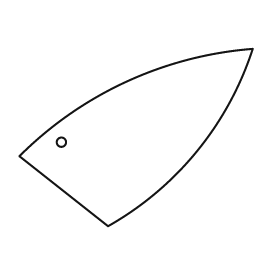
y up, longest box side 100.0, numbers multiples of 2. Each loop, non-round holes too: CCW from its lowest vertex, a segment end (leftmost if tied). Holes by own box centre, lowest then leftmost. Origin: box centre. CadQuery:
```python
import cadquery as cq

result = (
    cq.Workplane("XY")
    .moveTo(-12.0, -38.0)
    .threePointArc((26.0, -6.0), (50.0, 38.0))
    .threePointArc((-4.0, 24.0), (-50.0, -8.0))
    .close()
    .moveTo(-32.0, -2.0)
    .circle(2.0)
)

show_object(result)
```